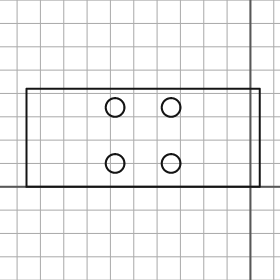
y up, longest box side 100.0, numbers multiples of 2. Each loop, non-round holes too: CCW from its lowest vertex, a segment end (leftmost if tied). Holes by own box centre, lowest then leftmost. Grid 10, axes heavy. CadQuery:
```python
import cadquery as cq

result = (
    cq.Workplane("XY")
    .moveTo(-96.0, 0.0)
    .lineTo(4.0, 0.0)
    .lineTo(4.0, 42.0)
    .lineTo(-96.0, 42.0)
    .close()
    .moveTo(-58.0, 10.0)
    .circle(4.0)
    .moveTo(-34.0, 10.0)
    .circle(4.0)
    .moveTo(-58.0, 34.0)
    .circle(4.0)
    .moveTo(-34.0, 34.0)
    .circle(4.0)
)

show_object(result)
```